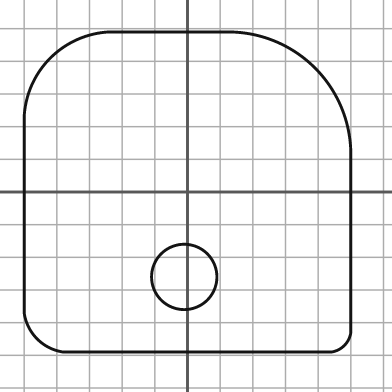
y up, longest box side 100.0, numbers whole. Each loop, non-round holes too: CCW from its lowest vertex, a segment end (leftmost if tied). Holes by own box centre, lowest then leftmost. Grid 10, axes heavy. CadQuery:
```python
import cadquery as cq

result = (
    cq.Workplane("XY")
    .moveTo(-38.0, -49.0)
    .lineTo(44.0, -49.0)
    .threePointArc((48.0, -47.0), (50.0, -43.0))
    .lineTo(50.0, 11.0)
    .threePointArc((39.0, 38.0), (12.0, 49.0))
    .lineTo(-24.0, 49.0)
    .threePointArc((-42.0, 41.0), (-50.0, 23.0))
    .lineTo(-50.0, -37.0)
    .threePointArc((-46.0, -45.0), (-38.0, -49.0))
    .close()
    .moveTo(-1.0, -26.0)
    .circle(10.0)
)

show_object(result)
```